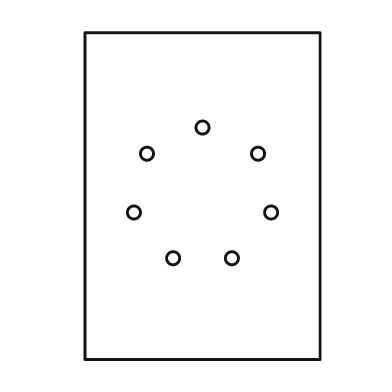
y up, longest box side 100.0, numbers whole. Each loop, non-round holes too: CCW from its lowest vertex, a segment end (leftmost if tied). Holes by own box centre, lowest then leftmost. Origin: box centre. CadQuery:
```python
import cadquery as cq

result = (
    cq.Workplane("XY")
    .moveTo(-36.0, -50.0)
    .lineTo(36.0, -50.0)
    .lineTo(36.0, 50.0)
    .lineTo(-36.0, 50.0)
    .close()
    .moveTo(-9.0, -19.0)
    .circle(2.0)
    .moveTo(9.0, -19.0)
    .circle(2.0)
    .moveTo(-21.0, -5.0)
    .circle(2.0)
    .moveTo(21.0, -5.0)
    .circle(2.0)
    .moveTo(-17.0, 13.0)
    .circle(2.0)
    .moveTo(17.0, 13.0)
    .circle(2.0)
    .moveTo(0.0, 21.0)
    .circle(2.0)
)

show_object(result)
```